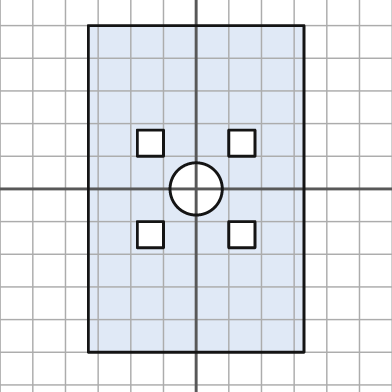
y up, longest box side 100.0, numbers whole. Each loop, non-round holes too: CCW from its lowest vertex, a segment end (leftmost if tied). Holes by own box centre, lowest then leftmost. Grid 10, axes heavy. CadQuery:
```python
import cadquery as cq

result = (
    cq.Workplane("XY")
    .moveTo(-33.0, -50.0)
    .lineTo(33.0, -50.0)
    .lineTo(33.0, 50.0)
    .lineTo(-33.0, 50.0)
    .close()
    .moveTo(-18.0, -18.0)
    .lineTo(-10.0, -18.0)
    .lineTo(-10.0, -10.0)
    .lineTo(-18.0, -10.0)
    .close()
    .moveTo(10.0, -18.0)
    .lineTo(18.0, -18.0)
    .lineTo(18.0, -10.0)
    .lineTo(10.0, -10.0)
    .close()
    .moveTo(0.0, 0.0)
    .circle(8.0)
    .moveTo(-18.0, 10.0)
    .lineTo(-10.0, 10.0)
    .lineTo(-10.0, 18.0)
    .lineTo(-18.0, 18.0)
    .close()
    .moveTo(10.0, 10.0)
    .lineTo(18.0, 10.0)
    .lineTo(18.0, 18.0)
    .lineTo(10.0, 18.0)
    .close()
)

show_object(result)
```